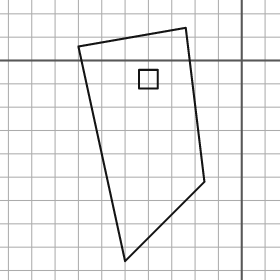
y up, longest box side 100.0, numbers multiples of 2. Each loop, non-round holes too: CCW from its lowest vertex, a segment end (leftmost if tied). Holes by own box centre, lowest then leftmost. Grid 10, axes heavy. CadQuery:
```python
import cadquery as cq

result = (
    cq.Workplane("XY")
    .moveTo(-50.0, -86.0)
    .lineTo(-16.0, -52.0)
    .lineTo(-24.0, 14.0)
    .lineTo(-70.0, 6.0)
    .close()
    .moveTo(-44.0, -12.0)
    .lineTo(-36.0, -12.0)
    .lineTo(-36.0, -4.0)
    .lineTo(-44.0, -4.0)
    .close()
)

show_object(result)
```